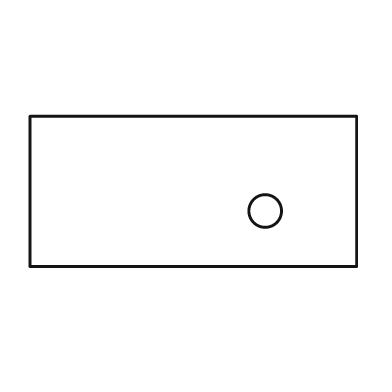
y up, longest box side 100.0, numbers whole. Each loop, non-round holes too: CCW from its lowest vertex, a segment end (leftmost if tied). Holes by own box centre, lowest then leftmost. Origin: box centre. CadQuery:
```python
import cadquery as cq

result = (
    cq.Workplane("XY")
    .moveTo(-50.0, -23.0)
    .lineTo(50.0, -23.0)
    .lineTo(50.0, 23.0)
    .lineTo(-50.0, 23.0)
    .close()
    .moveTo(22.0, -6.0)
    .circle(5.0)
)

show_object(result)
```